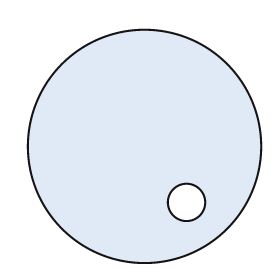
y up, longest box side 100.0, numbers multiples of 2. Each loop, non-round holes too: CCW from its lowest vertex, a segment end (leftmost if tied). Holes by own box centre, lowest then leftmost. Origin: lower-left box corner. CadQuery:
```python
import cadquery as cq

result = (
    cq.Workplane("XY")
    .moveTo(50.0, 50.0)
    .circle(50.0)
    .moveTo(68.0, 26.0)
    .circle(8.0)
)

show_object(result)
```